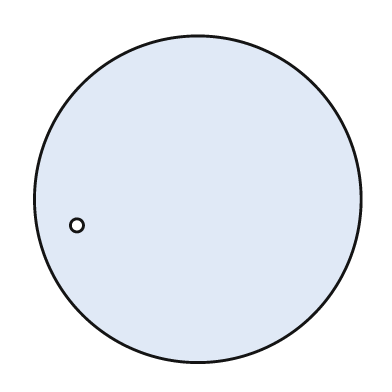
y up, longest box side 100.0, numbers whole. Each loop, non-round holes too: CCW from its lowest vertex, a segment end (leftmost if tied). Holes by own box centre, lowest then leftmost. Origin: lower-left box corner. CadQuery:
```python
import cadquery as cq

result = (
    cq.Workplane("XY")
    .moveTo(50.0, 50.0)
    .circle(50.0)
    .moveTo(13.0, 42.0)
    .circle(2.0)
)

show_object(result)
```